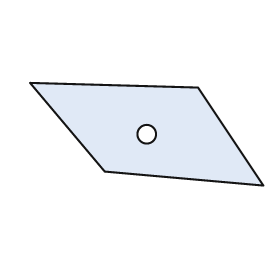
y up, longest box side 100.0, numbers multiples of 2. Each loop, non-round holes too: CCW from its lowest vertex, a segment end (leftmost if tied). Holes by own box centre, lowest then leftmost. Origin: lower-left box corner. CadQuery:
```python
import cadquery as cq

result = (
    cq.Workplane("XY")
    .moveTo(100.0, 0.0)
    .lineTo(72.0, 42.0)
    .lineTo(0.0, 44.0)
    .lineTo(32.0, 6.0)
    .close()
    .moveTo(50.0, 22.0)
    .circle(4.0)
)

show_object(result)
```